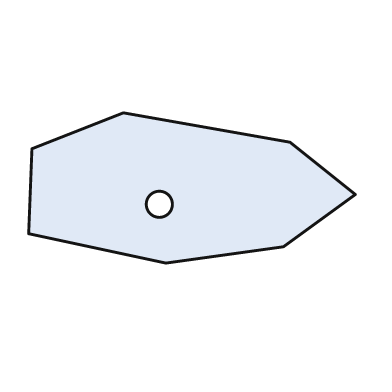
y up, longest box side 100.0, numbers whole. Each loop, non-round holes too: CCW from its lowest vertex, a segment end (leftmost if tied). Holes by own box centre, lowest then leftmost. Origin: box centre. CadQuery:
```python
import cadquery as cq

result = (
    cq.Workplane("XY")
    .moveTo(-8.0, -23.0)
    .lineTo(28.0, -18.0)
    .lineTo(50.0, -2.0)
    .lineTo(30.0, 14.0)
    .lineTo(-21.0, 23.0)
    .lineTo(-49.0, 12.0)
    .lineTo(-50.0, -14.0)
    .close()
    .moveTo(-10.0, -5.0)
    .circle(4.0)
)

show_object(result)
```